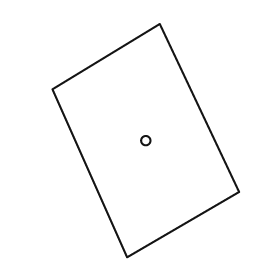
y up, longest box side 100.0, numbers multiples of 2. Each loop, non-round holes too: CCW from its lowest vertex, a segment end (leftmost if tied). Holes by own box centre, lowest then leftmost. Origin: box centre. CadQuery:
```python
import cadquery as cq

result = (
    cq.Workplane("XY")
    .moveTo(-8.0, -50.0)
    .lineTo(40.0, -22.0)
    .lineTo(6.0, 50.0)
    .lineTo(-40.0, 22.0)
    .close()
    .moveTo(0.0, 0.0)
    .circle(2.0)
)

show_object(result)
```